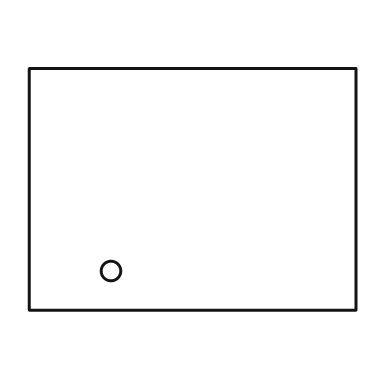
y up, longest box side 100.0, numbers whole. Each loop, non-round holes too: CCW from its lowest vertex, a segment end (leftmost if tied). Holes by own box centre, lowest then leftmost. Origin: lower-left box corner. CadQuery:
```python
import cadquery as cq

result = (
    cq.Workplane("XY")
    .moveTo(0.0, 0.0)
    .lineTo(100.0, 0.0)
    .lineTo(100.0, 74.0)
    .lineTo(0.0, 74.0)
    .close()
    .moveTo(25.0, 12.0)
    .circle(3.0)
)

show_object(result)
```